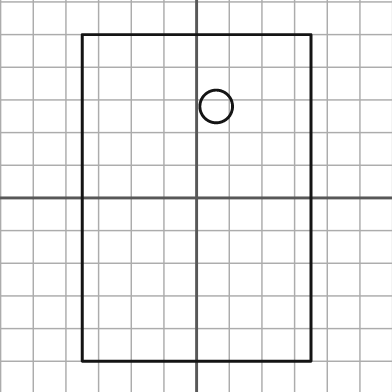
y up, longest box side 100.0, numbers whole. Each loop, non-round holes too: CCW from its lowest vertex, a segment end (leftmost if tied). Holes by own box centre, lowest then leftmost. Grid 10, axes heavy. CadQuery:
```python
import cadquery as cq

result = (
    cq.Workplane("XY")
    .moveTo(-35.0, -50.0)
    .lineTo(35.0, -50.0)
    .lineTo(35.0, 50.0)
    .lineTo(-35.0, 50.0)
    .close()
    .moveTo(6.0, 28.0)
    .circle(5.0)
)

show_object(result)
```